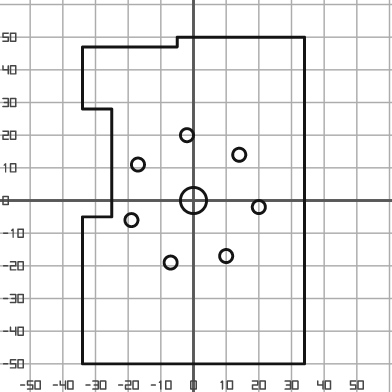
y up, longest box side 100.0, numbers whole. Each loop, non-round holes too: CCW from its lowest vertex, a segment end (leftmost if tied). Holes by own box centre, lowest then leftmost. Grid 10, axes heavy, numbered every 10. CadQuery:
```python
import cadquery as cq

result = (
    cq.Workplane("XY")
    .moveTo(-34.0, -50.0)
    .lineTo(34.0, -50.0)
    .lineTo(34.0, 50.0)
    .lineTo(-5.0, 50.0)
    .lineTo(-5.0, 47.0)
    .lineTo(-34.0, 47.0)
    .lineTo(-34.0, 28.0)
    .lineTo(-25.0, 28.0)
    .lineTo(-25.0, -5.0)
    .lineTo(-34.0, -5.0)
    .close()
    .moveTo(-7.0, -19.0)
    .circle(2.0)
    .moveTo(10.0, -17.0)
    .circle(2.0)
    .moveTo(-19.0, -6.0)
    .circle(2.0)
    .moveTo(20.0, -2.0)
    .circle(2.0)
    .moveTo(0.0, 0.0)
    .circle(4.0)
    .moveTo(-17.0, 11.0)
    .circle(2.0)
    .moveTo(14.0, 14.0)
    .circle(2.0)
    .moveTo(-2.0, 20.0)
    .circle(2.0)
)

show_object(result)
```